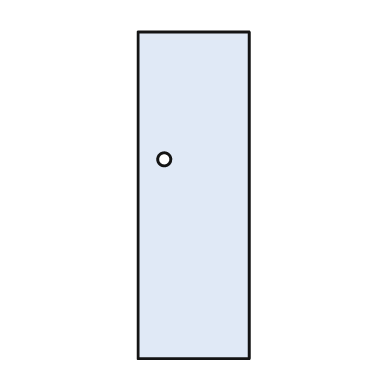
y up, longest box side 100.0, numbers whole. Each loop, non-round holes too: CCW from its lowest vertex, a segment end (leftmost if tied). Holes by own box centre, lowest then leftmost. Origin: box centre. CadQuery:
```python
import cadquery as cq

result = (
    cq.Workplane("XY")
    .moveTo(-17.0, -50.0)
    .lineTo(17.0, -50.0)
    .lineTo(17.0, 50.0)
    .lineTo(-17.0, 50.0)
    .close()
    .moveTo(-9.0, 11.0)
    .circle(2.0)
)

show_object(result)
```